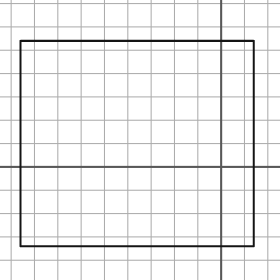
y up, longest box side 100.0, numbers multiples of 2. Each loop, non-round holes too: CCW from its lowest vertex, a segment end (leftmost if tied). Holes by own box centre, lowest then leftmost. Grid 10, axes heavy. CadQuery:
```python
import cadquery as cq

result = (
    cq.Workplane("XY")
    .moveTo(-86.0, -34.0)
    .lineTo(14.0, -34.0)
    .lineTo(14.0, 54.0)
    .lineTo(-86.0, 54.0)
    .close()
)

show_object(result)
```